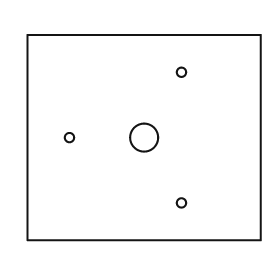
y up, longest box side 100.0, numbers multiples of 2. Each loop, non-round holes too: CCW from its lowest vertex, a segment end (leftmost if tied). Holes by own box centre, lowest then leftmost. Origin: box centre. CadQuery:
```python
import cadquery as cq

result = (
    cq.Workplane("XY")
    .moveTo(-50.0, -44.0)
    .lineTo(50.0, -44.0)
    .lineTo(50.0, 44.0)
    .lineTo(-50.0, 44.0)
    .close()
    .moveTo(16.0, -28.0)
    .circle(2.0)
    .moveTo(-32.0, 0.0)
    .circle(2.0)
    .moveTo(0.0, 0.0)
    .circle(6.0)
    .moveTo(16.0, 28.0)
    .circle(2.0)
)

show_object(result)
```